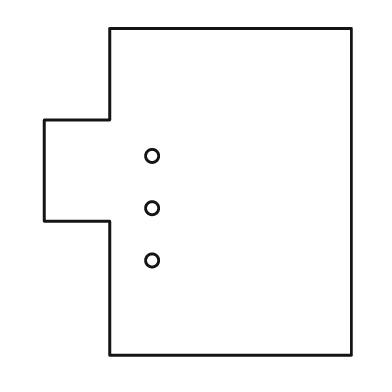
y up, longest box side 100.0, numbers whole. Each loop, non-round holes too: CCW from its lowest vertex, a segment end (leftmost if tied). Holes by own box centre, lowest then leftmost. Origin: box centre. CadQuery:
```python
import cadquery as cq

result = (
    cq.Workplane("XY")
    .moveTo(-27.0, -50.0)
    .lineTo(47.0, -50.0)
    .lineTo(47.0, 50.0)
    .lineTo(-27.0, 50.0)
    .lineTo(-27.0, 22.0)
    .lineTo(-47.0, 22.0)
    .lineTo(-47.0, -9.0)
    .lineTo(-27.0, -9.0)
    .close()
    .moveTo(-14.0, -21.0)
    .circle(2.0)
    .moveTo(-14.0, -5.0)
    .circle(2.0)
    .moveTo(-14.0, 11.0)
    .circle(2.0)
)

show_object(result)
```